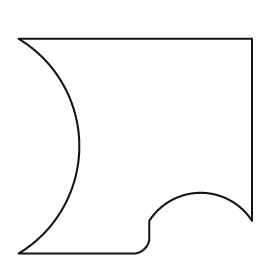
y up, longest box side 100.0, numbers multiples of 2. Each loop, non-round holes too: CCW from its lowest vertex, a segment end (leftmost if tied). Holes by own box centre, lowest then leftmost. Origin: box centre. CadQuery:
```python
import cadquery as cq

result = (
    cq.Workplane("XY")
    .moveTo(-50.0, -46.0)
    .lineTo(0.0, -46.0)
    .threePointArc((4.0, -44.0), (6.0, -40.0))
    .lineTo(6.0, -32.0)
    .threePointArc((28.0, -20.0), (50.0, -32.0))
    .lineTo(50.0, 46.0)
    .lineTo(-50.0, 46.0)
    .threePointArc((-24.0, 0.0), (-50.0, -46.0))
    .close()
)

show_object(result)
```